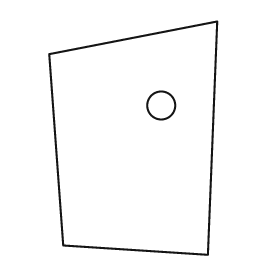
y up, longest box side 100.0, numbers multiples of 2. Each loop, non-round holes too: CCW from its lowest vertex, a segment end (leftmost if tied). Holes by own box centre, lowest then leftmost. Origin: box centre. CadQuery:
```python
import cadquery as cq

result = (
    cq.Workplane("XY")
    .moveTo(32.0, -50.0)
    .lineTo(36.0, 50.0)
    .lineTo(-36.0, 36.0)
    .lineTo(-30.0, -46.0)
    .close()
    .moveTo(12.0, 14.0)
    .circle(6.0)
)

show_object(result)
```